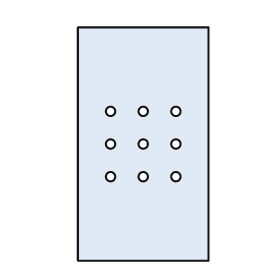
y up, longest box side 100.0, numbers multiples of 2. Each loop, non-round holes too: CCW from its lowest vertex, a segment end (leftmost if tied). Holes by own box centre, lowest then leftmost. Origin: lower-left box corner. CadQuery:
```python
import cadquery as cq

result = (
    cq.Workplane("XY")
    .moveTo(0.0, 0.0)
    .lineTo(56.0, 0.0)
    .lineTo(56.0, 100.0)
    .lineTo(0.0, 100.0)
    .close()
    .moveTo(14.0, 36.0)
    .circle(2.0)
    .moveTo(28.0, 36.0)
    .circle(2.0)
    .moveTo(42.0, 36.0)
    .circle(2.0)
    .moveTo(14.0, 50.0)
    .circle(2.0)
    .moveTo(28.0, 50.0)
    .circle(2.0)
    .moveTo(42.0, 50.0)
    .circle(2.0)
    .moveTo(14.0, 64.0)
    .circle(2.0)
    .moveTo(28.0, 64.0)
    .circle(2.0)
    .moveTo(42.0, 64.0)
    .circle(2.0)
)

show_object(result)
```